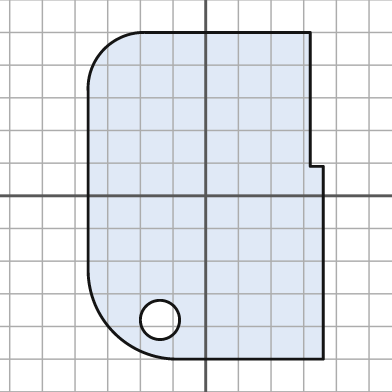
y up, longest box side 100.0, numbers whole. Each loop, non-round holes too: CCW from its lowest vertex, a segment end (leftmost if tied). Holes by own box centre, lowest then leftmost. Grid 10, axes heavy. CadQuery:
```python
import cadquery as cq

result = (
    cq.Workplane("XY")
    .moveTo(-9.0, -50.0)
    .lineTo(36.0, -50.0)
    .lineTo(36.0, 9.0)
    .lineTo(32.0, 9.0)
    .lineTo(32.0, 50.0)
    .lineTo(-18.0, 50.0)
    .threePointArc((-31.0, 45.0), (-36.0, 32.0))
    .lineTo(-36.0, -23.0)
    .threePointArc((-28.0, -42.0), (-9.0, -50.0))
    .close()
    .moveTo(-14.0, -38.0)
    .circle(6.0)
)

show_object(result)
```